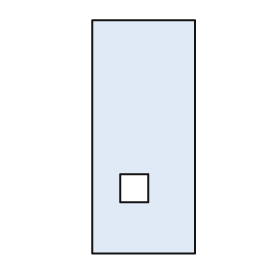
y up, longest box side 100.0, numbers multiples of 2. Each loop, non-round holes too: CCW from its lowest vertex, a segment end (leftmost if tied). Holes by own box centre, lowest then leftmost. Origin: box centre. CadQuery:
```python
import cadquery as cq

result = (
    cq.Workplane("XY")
    .moveTo(-22.0, -50.0)
    .lineTo(22.0, -50.0)
    .lineTo(22.0, 50.0)
    .lineTo(-22.0, 50.0)
    .close()
    .moveTo(-10.0, -28.0)
    .lineTo(2.0, -28.0)
    .lineTo(2.0, -16.0)
    .lineTo(-10.0, -16.0)
    .close()
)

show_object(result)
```